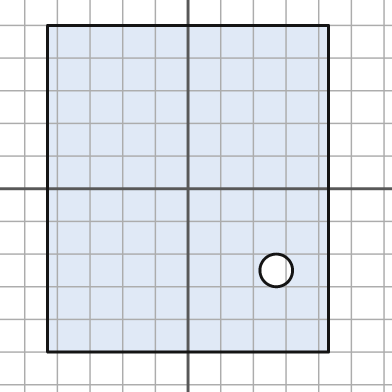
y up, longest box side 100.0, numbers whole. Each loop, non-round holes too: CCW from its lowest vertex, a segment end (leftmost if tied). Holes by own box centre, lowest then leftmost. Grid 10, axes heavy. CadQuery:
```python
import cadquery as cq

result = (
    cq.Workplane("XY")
    .moveTo(-43.0, -50.0)
    .lineTo(43.0, -50.0)
    .lineTo(43.0, 50.0)
    .lineTo(-43.0, 50.0)
    .close()
    .moveTo(27.0, -25.0)
    .circle(5.0)
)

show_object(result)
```